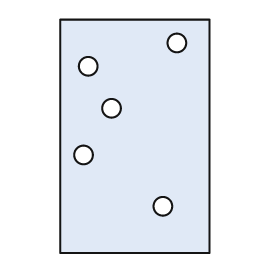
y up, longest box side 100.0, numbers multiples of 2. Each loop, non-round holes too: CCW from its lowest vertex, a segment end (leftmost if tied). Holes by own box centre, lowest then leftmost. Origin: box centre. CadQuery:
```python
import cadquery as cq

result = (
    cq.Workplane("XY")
    .moveTo(-32.0, -50.0)
    .lineTo(32.0, -50.0)
    .lineTo(32.0, 50.0)
    .lineTo(-32.0, 50.0)
    .close()
    .moveTo(12.0, -30.0)
    .circle(4.0)
    .moveTo(-22.0, -8.0)
    .circle(4.0)
    .moveTo(-10.0, 12.0)
    .circle(4.0)
    .moveTo(-20.0, 30.0)
    .circle(4.0)
    .moveTo(18.0, 40.0)
    .circle(4.0)
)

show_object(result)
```